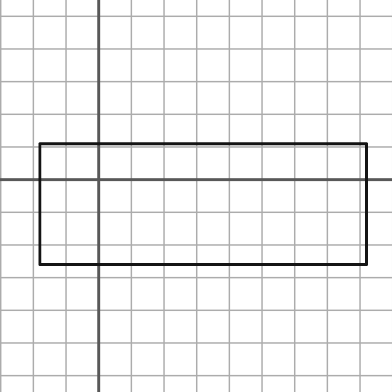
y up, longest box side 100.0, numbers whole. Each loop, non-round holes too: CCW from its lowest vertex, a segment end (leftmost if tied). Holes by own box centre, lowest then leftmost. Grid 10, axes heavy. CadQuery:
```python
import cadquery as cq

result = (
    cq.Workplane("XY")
    .moveTo(-18.0, -26.0)
    .lineTo(82.0, -26.0)
    .lineTo(82.0, 11.0)
    .lineTo(-18.0, 11.0)
    .close()
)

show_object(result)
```